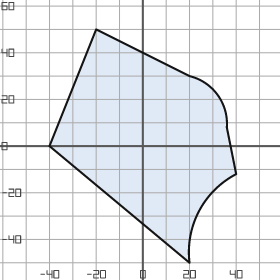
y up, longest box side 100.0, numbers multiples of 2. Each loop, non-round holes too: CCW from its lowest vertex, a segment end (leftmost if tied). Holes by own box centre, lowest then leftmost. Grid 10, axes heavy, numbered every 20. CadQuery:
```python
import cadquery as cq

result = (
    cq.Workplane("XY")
    .moveTo(20.0, -50.0)
    .threePointArc((24.0, -28.0), (40.0, -12.0))
    .lineTo(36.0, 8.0)
    .threePointArc((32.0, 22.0), (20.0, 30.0))
    .lineTo(-20.0, 50.0)
    .lineTo(-40.0, 0.0)
    .close()
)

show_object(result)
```